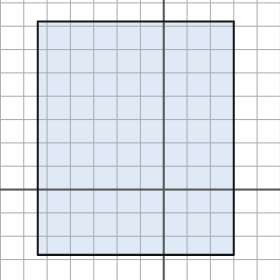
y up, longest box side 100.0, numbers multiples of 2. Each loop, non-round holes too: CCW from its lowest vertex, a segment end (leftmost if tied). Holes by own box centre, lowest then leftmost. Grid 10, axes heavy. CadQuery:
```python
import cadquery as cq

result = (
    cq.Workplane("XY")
    .moveTo(-54.0, -28.0)
    .lineTo(30.0, -28.0)
    .lineTo(30.0, 72.0)
    .lineTo(-54.0, 72.0)
    .close()
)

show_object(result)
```